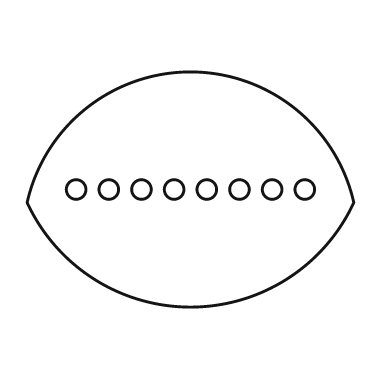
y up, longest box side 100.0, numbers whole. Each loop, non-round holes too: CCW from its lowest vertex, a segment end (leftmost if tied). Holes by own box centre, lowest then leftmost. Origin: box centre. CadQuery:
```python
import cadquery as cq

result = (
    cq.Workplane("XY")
    .moveTo(-50.0, -4.0)
    .threePointArc((0.0, -36.0), (50.0, -4.0))
    .threePointArc((0.0, 36.0), (-50.0, -4.0))
    .close()
    .moveTo(-35.0, 0.0)
    .circle(3.0)
    .moveTo(-25.0, 0.0)
    .circle(3.0)
    .moveTo(-15.0, 0.0)
    .circle(3.0)
    .moveTo(-5.0, 0.0)
    .circle(3.0)
    .moveTo(5.0, 0.0)
    .circle(3.0)
    .moveTo(15.0, 0.0)
    .circle(3.0)
    .moveTo(25.0, 0.0)
    .circle(3.0)
    .moveTo(35.0, 0.0)
    .circle(3.0)
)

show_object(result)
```